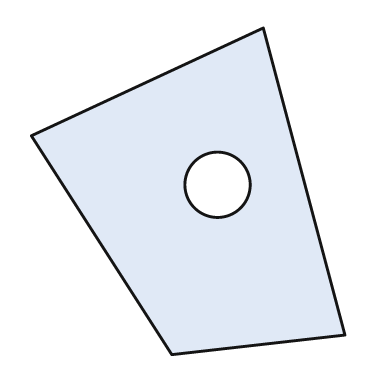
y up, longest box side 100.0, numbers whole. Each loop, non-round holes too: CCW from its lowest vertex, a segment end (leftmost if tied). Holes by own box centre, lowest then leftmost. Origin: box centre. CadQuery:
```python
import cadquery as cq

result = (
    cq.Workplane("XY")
    .moveTo(-5.0, -50.0)
    .lineTo(48.0, -44.0)
    .lineTo(23.0, 50.0)
    .lineTo(-48.0, 17.0)
    .close()
    .moveTo(9.0, 2.0)
    .circle(10.0)
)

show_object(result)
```